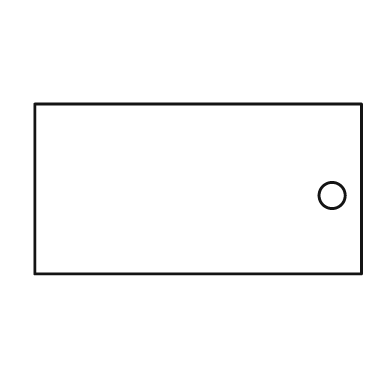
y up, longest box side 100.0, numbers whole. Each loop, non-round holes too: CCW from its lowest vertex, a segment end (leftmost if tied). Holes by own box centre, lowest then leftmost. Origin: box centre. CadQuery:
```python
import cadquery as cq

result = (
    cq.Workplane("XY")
    .moveTo(-50.0, -26.0)
    .lineTo(50.0, -26.0)
    .lineTo(50.0, 26.0)
    .lineTo(-50.0, 26.0)
    .close()
    .moveTo(41.0, -2.0)
    .circle(4.0)
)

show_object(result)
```